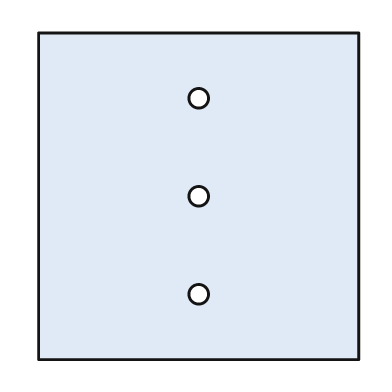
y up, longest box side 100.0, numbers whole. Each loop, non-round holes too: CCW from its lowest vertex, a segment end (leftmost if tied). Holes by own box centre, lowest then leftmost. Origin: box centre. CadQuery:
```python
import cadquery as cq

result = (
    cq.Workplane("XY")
    .moveTo(-49.0, -50.0)
    .lineTo(49.0, -50.0)
    .lineTo(49.0, 50.0)
    .lineTo(-49.0, 50.0)
    .close()
    .moveTo(0.0, -30.0)
    .circle(3.0)
    .moveTo(0.0, 0.0)
    .circle(3.0)
    .moveTo(0.0, 30.0)
    .circle(3.0)
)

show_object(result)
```